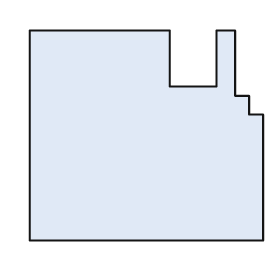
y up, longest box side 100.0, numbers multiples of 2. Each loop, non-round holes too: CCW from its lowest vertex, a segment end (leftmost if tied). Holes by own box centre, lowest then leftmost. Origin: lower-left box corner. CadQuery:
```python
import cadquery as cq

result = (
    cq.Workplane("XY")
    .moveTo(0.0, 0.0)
    .lineTo(100.0, 0.0)
    .lineTo(100.0, 54.0)
    .lineTo(94.0, 54.0)
    .lineTo(94.0, 62.0)
    .lineTo(88.0, 62.0)
    .lineTo(88.0, 90.0)
    .lineTo(80.0, 90.0)
    .lineTo(80.0, 66.0)
    .lineTo(60.0, 66.0)
    .lineTo(60.0, 90.0)
    .lineTo(0.0, 90.0)
    .close()
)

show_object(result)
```